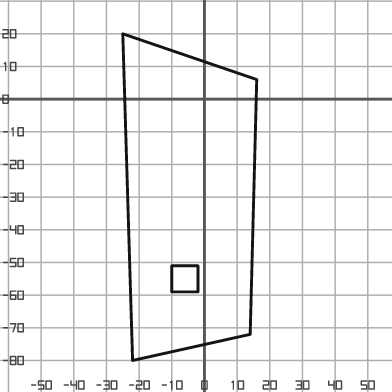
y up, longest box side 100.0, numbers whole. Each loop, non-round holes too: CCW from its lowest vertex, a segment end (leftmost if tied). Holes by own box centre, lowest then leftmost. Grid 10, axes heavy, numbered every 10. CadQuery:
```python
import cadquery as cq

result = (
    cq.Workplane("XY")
    .moveTo(-22.0, -80.0)
    .lineTo(14.0, -72.0)
    .lineTo(16.0, 6.0)
    .lineTo(-25.0, 20.0)
    .close()
    .moveTo(-10.0, -59.0)
    .lineTo(-2.0, -59.0)
    .lineTo(-2.0, -51.0)
    .lineTo(-10.0, -51.0)
    .close()
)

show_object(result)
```